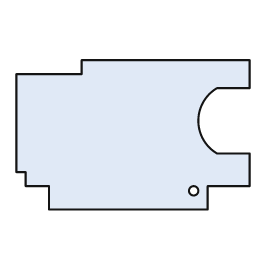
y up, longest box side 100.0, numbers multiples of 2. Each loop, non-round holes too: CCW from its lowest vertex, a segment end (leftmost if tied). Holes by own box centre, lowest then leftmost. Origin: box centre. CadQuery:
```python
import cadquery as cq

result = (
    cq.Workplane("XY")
    .moveTo(-36.0, -32.0)
    .lineTo(32.0, -32.0)
    .lineTo(32.0, -22.0)
    .lineTo(50.0, -22.0)
    .lineTo(50.0, -8.0)
    .lineTo(36.0, -8.0)
    .threePointArc((28.0, 6.0), (36.0, 20.0))
    .lineTo(50.0, 20.0)
    .lineTo(50.0, 32.0)
    .lineTo(-22.0, 32.0)
    .lineTo(-22.0, 26.0)
    .lineTo(-50.0, 26.0)
    .lineTo(-50.0, -16.0)
    .lineTo(-46.0, -16.0)
    .lineTo(-46.0, -22.0)
    .lineTo(-36.0, -22.0)
    .close()
    .moveTo(26.0, -24.0)
    .circle(2.0)
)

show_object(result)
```